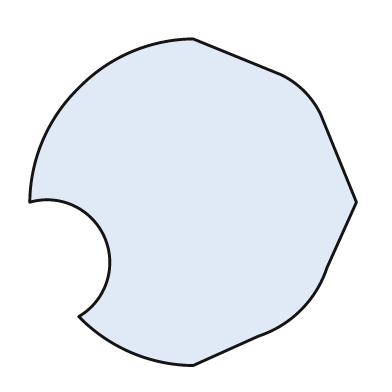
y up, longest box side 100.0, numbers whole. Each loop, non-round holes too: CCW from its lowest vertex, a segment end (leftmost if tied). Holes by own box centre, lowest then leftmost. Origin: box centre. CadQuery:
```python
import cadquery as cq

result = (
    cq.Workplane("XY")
    .moveTo(0.0, -50.0)
    .lineTo(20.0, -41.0)
    .threePointArc((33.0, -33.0), (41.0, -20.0))
    .lineTo(50.0, 0.0)
    .lineTo(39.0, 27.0)
    .threePointArc((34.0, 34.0), (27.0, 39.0))
    .lineTo(0.0, 50.0)
    .threePointArc((-19.0, 46.0), (-35.0, 35.0))
    .threePointArc((-46.0, 19.0), (-50.0, 0.0))
    .threePointArc((-27.0, -11.0), (-35.0, -35.0))
    .threePointArc((-19.0, -46.0), (0.0, -50.0))
    .close()
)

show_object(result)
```